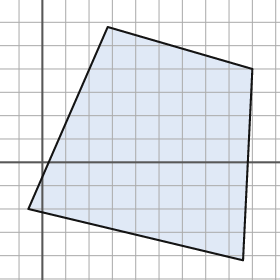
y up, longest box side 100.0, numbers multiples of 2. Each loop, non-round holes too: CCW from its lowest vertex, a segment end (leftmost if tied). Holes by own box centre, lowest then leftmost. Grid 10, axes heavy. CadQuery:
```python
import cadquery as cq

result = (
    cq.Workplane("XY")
    .moveTo(86.0, -42.0)
    .lineTo(90.0, 40.0)
    .lineTo(28.0, 58.0)
    .lineTo(-6.0, -20.0)
    .close()
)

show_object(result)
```